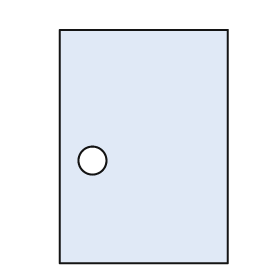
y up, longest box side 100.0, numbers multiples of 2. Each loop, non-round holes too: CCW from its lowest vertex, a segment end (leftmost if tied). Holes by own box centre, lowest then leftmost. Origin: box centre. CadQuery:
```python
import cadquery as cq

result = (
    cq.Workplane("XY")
    .moveTo(-36.0, -50.0)
    .lineTo(36.0, -50.0)
    .lineTo(36.0, 50.0)
    .lineTo(-36.0, 50.0)
    .close()
    .moveTo(-22.0, -6.0)
    .circle(6.0)
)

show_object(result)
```